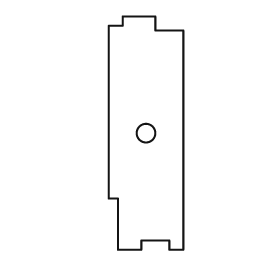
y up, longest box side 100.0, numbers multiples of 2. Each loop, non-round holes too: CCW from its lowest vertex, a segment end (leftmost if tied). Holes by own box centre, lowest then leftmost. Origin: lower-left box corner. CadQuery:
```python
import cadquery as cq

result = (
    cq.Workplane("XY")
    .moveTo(4.0, 0.0)
    .lineTo(14.0, 0.0)
    .lineTo(14.0, 4.0)
    .lineTo(26.0, 4.0)
    .lineTo(26.0, 0.0)
    .lineTo(32.0, 0.0)
    .lineTo(32.0, 94.0)
    .lineTo(20.0, 94.0)
    .lineTo(20.0, 100.0)
    .lineTo(6.0, 100.0)
    .lineTo(6.0, 96.0)
    .lineTo(0.0, 96.0)
    .lineTo(0.0, 22.0)
    .lineTo(4.0, 22.0)
    .close()
    .moveTo(16.0, 50.0)
    .circle(4.0)
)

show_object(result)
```